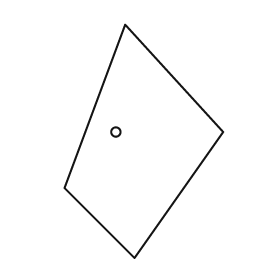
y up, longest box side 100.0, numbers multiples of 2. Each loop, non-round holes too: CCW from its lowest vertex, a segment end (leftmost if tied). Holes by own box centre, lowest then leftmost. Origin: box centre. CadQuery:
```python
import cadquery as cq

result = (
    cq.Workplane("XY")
    .moveTo(-4.0, -50.0)
    .lineTo(34.0, 4.0)
    .lineTo(-8.0, 50.0)
    .lineTo(-34.0, -20.0)
    .close()
    .moveTo(-12.0, 4.0)
    .circle(2.0)
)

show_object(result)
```